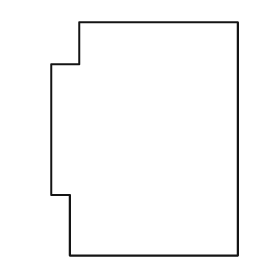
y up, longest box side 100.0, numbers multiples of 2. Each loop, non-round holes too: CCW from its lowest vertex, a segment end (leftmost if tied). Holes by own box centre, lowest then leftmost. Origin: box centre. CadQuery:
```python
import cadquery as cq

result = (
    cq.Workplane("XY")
    .moveTo(-32.0, -50.0)
    .lineTo(40.0, -50.0)
    .lineTo(40.0, 50.0)
    .lineTo(-28.0, 50.0)
    .lineTo(-28.0, 32.0)
    .lineTo(-40.0, 32.0)
    .lineTo(-40.0, -24.0)
    .lineTo(-32.0, -24.0)
    .close()
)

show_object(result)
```